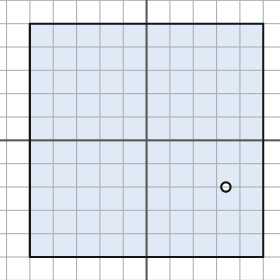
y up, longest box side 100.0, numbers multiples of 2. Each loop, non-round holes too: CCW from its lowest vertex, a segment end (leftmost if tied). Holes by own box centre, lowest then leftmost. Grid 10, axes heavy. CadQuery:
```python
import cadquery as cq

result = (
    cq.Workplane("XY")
    .moveTo(-50.0, -50.0)
    .lineTo(50.0, -50.0)
    .lineTo(50.0, 50.0)
    .lineTo(-50.0, 50.0)
    .close()
    .moveTo(34.0, -20.0)
    .circle(2.0)
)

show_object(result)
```